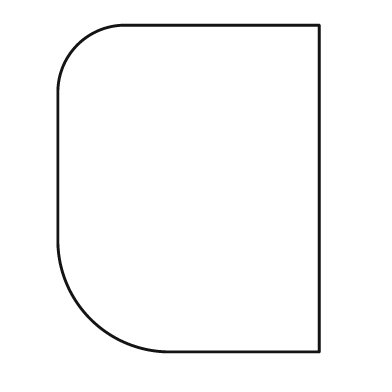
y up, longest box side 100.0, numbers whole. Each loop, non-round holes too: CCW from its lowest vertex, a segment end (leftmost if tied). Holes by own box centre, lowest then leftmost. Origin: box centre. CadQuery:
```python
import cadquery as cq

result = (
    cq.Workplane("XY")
    .moveTo(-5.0, -50.0)
    .lineTo(40.0, -50.0)
    .lineTo(40.0, 50.0)
    .lineTo(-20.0, 50.0)
    .threePointArc((-34.0, 44.0), (-40.0, 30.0))
    .lineTo(-40.0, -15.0)
    .threePointArc((-30.0, -40.0), (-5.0, -50.0))
    .close()
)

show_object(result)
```